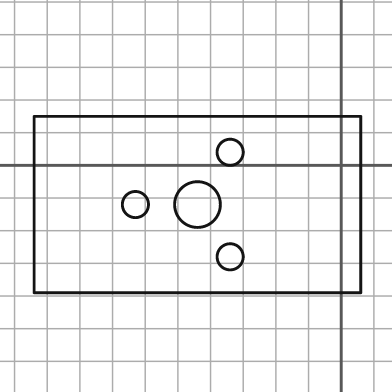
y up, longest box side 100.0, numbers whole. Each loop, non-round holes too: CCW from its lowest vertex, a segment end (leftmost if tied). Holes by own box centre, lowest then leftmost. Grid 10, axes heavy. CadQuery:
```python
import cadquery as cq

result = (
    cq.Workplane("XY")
    .moveTo(-94.0, -39.0)
    .lineTo(6.0, -39.0)
    .lineTo(6.0, 15.0)
    .lineTo(-94.0, 15.0)
    .close()
    .moveTo(-34.0, -28.0)
    .circle(4.0)
    .moveTo(-63.0, -12.0)
    .circle(4.0)
    .moveTo(-44.0, -12.0)
    .circle(7.0)
    .moveTo(-34.0, 4.0)
    .circle(4.0)
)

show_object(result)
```